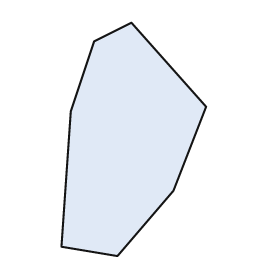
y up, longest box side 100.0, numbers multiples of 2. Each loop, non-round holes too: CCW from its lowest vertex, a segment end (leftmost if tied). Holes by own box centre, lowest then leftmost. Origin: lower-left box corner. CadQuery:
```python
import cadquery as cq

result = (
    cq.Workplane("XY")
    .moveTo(24.0, 0.0)
    .lineTo(48.0, 28.0)
    .lineTo(62.0, 64.0)
    .lineTo(30.0, 100.0)
    .lineTo(14.0, 92.0)
    .lineTo(4.0, 62.0)
    .lineTo(0.0, 4.0)
    .close()
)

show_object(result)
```